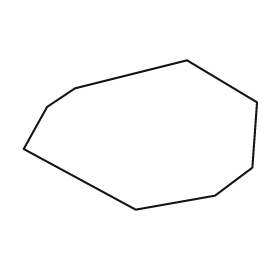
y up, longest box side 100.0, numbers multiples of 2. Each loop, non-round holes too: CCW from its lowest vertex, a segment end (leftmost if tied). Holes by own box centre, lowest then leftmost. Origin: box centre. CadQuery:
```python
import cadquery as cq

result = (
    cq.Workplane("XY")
    .moveTo(-2.0, -32.0)
    .lineTo(32.0, -26.0)
    .lineTo(48.0, -14.0)
    .lineTo(50.0, 14.0)
    .lineTo(20.0, 32.0)
    .lineTo(-28.0, 20.0)
    .lineTo(-40.0, 12.0)
    .lineTo(-50.0, -6.0)
    .close()
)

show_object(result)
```